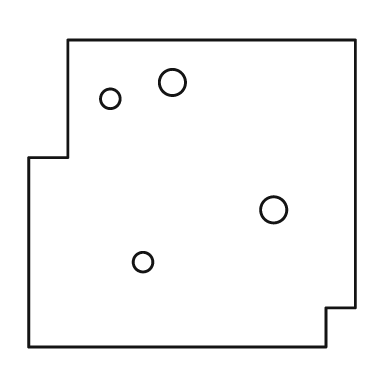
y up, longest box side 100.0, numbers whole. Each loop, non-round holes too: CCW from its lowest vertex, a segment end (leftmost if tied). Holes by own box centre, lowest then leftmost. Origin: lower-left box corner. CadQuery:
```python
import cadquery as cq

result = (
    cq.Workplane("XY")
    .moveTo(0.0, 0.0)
    .lineTo(91.0, 0.0)
    .lineTo(91.0, 12.0)
    .lineTo(100.0, 12.0)
    .lineTo(100.0, 94.0)
    .lineTo(12.0, 94.0)
    .lineTo(12.0, 58.0)
    .lineTo(0.0, 58.0)
    .close()
    .moveTo(35.0, 26.0)
    .circle(3.0)
    .moveTo(75.0, 42.0)
    .circle(4.0)
    .moveTo(25.0, 76.0)
    .circle(3.0)
    .moveTo(44.0, 81.0)
    .circle(4.0)
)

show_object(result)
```